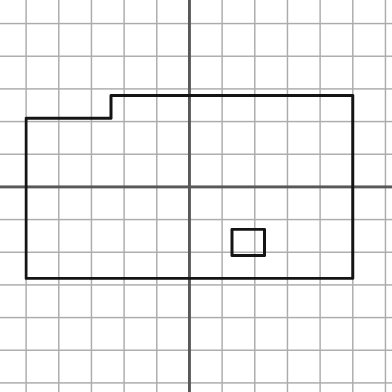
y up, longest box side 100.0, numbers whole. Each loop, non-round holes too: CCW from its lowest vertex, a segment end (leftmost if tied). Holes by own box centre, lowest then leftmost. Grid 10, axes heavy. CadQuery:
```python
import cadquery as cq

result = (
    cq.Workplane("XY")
    .moveTo(-50.0, -28.0)
    .lineTo(50.0, -28.0)
    .lineTo(50.0, 28.0)
    .lineTo(-24.0, 28.0)
    .lineTo(-24.0, 21.0)
    .lineTo(-50.0, 21.0)
    .close()
    .moveTo(13.0, -21.0)
    .lineTo(23.0, -21.0)
    .lineTo(23.0, -13.0)
    .lineTo(13.0, -13.0)
    .close()
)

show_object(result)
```